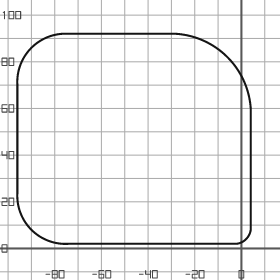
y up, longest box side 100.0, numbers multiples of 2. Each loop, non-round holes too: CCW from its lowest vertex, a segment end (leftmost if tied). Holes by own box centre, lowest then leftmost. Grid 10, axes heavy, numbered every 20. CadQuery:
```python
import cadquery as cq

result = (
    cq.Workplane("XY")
    .moveTo(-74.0, 2.0)
    .lineTo(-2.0, 2.0)
    .threePointArc((2.0, 4.0), (4.0, 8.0))
    .lineTo(4.0, 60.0)
    .threePointArc((-6.0, 82.0), (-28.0, 92.0))
    .lineTo(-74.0, 92.0)
    .threePointArc((-90.0, 86.0), (-96.0, 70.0))
    .lineTo(-96.0, 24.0)
    .threePointArc((-90.0, 8.0), (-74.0, 2.0))
    .close()
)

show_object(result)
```